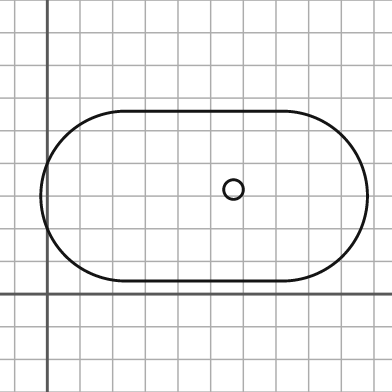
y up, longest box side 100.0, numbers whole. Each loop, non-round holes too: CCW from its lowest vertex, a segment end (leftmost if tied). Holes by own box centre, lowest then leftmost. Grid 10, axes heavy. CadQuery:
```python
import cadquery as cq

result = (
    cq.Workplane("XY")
    .moveTo(24.0, 4.0)
    .lineTo(72.0, 4.0)
    .threePointArc((98.0, 30.0), (72.0, 56.0))
    .lineTo(24.0, 56.0)
    .threePointArc((-2.0, 30.0), (24.0, 4.0))
    .close()
    .moveTo(57.0, 32.0)
    .circle(3.0)
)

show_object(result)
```